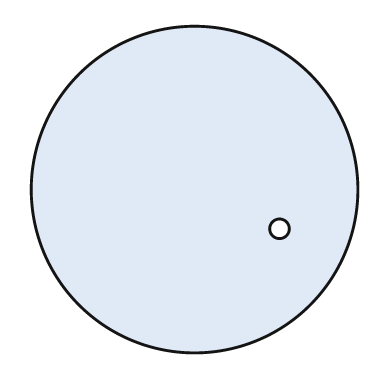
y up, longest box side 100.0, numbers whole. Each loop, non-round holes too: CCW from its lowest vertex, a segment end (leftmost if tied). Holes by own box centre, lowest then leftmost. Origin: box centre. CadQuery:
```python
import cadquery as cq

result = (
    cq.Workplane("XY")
    .moveTo(0.0, 0.0)
    .circle(50.0)
    .moveTo(26.0, -12.0)
    .circle(3.0)
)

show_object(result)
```